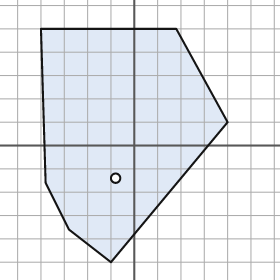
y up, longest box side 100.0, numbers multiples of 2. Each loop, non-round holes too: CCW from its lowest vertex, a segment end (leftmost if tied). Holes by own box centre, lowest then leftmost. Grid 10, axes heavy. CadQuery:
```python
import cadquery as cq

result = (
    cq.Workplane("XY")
    .moveTo(-10.0, -50.0)
    .lineTo(40.0, 10.0)
    .lineTo(18.0, 50.0)
    .lineTo(-40.0, 50.0)
    .lineTo(-38.0, -16.0)
    .lineTo(-28.0, -36.0)
    .close()
    .moveTo(-8.0, -14.0)
    .circle(2.0)
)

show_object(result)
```